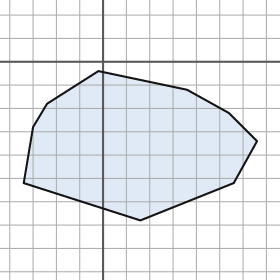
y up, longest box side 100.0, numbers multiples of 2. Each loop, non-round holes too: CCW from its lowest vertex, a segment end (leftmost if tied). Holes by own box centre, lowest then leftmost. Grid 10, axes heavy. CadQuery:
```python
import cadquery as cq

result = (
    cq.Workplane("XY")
    .moveTo(16.0, -68.0)
    .lineTo(56.0, -52.0)
    .lineTo(66.0, -34.0)
    .lineTo(54.0, -22.0)
    .lineTo(36.0, -12.0)
    .lineTo(-2.0, -4.0)
    .lineTo(-24.0, -18.0)
    .lineTo(-30.0, -28.0)
    .lineTo(-34.0, -52.0)
    .close()
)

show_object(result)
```